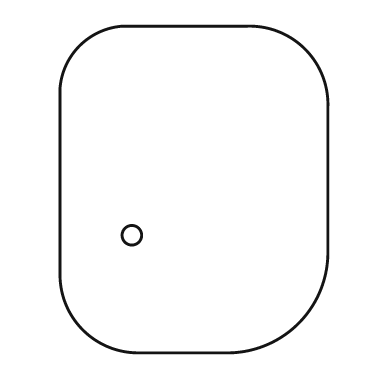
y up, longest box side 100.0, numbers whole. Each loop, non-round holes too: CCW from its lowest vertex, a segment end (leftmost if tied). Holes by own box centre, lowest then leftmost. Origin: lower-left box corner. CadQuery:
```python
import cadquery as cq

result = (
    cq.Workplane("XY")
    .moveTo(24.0, 0.0)
    .lineTo(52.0, 0.0)
    .threePointArc((73.0, 9.0), (82.0, 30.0))
    .lineTo(82.0, 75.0)
    .threePointArc((75.0, 93.0), (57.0, 100.0))
    .lineTo(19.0, 100.0)
    .threePointArc((6.0, 94.0), (0.0, 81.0))
    .lineTo(0.0, 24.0)
    .threePointArc((7.0, 7.0), (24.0, 0.0))
    .close()
    .moveTo(22.0, 36.0)
    .circle(3.0)
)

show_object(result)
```